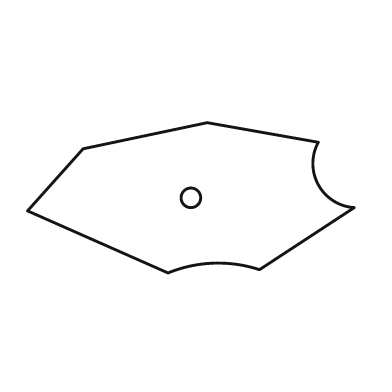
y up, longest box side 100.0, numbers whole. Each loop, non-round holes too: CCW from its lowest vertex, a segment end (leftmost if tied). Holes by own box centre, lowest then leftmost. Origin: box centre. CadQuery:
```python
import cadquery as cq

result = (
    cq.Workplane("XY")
    .moveTo(-7.0, -23.0)
    .threePointArc((7.0, -20.0), (21.0, -22.0))
    .lineTo(50.0, -3.0)
    .threePointArc((39.0, 4.0), (39.0, 17.0))
    .lineTo(5.0, 23.0)
    .lineTo(-33.0, 15.0)
    .lineTo(-50.0, -4.0)
    .close()
    .moveTo(0.0, 0.0)
    .circle(3.0)
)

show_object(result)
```